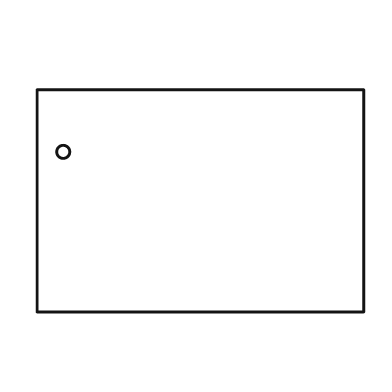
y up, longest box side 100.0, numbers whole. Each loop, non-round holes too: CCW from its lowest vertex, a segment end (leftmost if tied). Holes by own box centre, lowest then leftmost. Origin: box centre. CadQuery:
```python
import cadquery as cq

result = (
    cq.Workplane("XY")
    .moveTo(-50.0, -34.0)
    .lineTo(50.0, -34.0)
    .lineTo(50.0, 34.0)
    .lineTo(-50.0, 34.0)
    .close()
    .moveTo(-42.0, 15.0)
    .circle(2.0)
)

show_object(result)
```